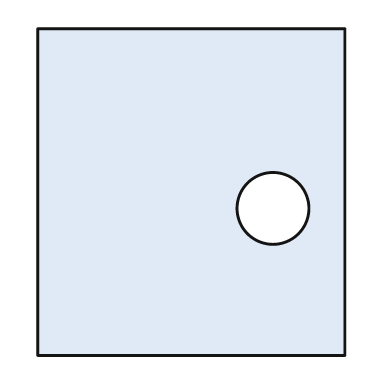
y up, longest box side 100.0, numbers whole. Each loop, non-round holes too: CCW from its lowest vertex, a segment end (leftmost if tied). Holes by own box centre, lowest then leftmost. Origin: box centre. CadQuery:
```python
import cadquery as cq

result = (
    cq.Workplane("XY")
    .moveTo(-47.0, -50.0)
    .lineTo(47.0, -50.0)
    .lineTo(47.0, 50.0)
    .lineTo(-47.0, 50.0)
    .close()
    .moveTo(25.0, -5.0)
    .circle(11.0)
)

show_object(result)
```